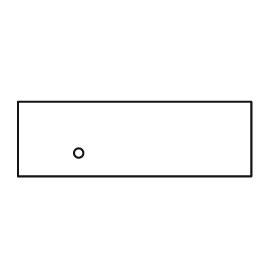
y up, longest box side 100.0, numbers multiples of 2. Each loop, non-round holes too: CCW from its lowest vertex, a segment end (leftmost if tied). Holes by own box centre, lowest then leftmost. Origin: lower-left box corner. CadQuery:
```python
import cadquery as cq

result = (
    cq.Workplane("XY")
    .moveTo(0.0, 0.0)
    .lineTo(100.0, 0.0)
    .lineTo(100.0, 32.0)
    .lineTo(0.0, 32.0)
    .close()
    .moveTo(26.0, 10.0)
    .circle(2.0)
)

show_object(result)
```